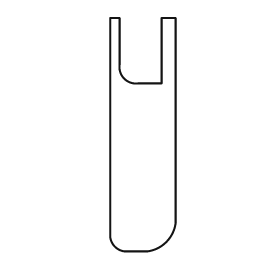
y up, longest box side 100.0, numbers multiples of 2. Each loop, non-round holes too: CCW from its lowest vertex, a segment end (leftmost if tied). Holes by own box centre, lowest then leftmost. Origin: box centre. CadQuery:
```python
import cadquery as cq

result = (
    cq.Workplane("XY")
    .moveTo(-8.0, -50.0)
    .lineTo(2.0, -50.0)
    .threePointArc((10.0, -46.0), (14.0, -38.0))
    .lineTo(14.0, 50.0)
    .lineTo(8.0, 50.0)
    .lineTo(8.0, 22.0)
    .lineTo(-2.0, 22.0)
    .threePointArc((-8.0, 24.0), (-10.0, 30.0))
    .lineTo(-10.0, 50.0)
    .lineTo(-14.0, 50.0)
    .lineTo(-14.0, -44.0)
    .threePointArc((-12.0, -48.0), (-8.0, -50.0))
    .close()
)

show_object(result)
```